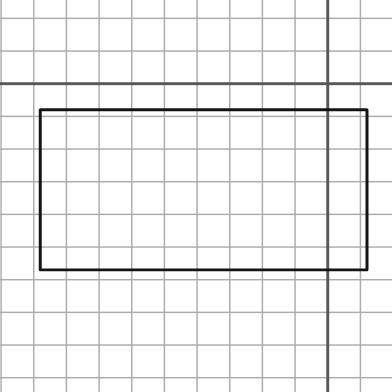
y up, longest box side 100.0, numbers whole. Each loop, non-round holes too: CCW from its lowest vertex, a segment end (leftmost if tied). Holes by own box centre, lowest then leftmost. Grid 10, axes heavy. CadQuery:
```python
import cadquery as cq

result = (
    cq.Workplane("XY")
    .moveTo(-88.0, -57.0)
    .lineTo(12.0, -57.0)
    .lineTo(12.0, -8.0)
    .lineTo(-88.0, -8.0)
    .close()
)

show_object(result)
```